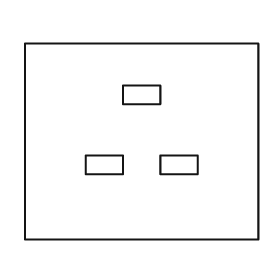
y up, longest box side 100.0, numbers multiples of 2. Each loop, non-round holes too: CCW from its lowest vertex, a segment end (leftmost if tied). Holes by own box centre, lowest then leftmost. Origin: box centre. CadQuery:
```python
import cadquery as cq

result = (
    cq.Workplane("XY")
    .moveTo(-50.0, -42.0)
    .lineTo(50.0, -42.0)
    .lineTo(50.0, 42.0)
    .lineTo(-50.0, 42.0)
    .close()
    .moveTo(-24.0, -14.0)
    .lineTo(-8.0, -14.0)
    .lineTo(-8.0, -6.0)
    .lineTo(-24.0, -6.0)
    .close()
    .moveTo(8.0, -14.0)
    .lineTo(24.0, -14.0)
    .lineTo(24.0, -6.0)
    .lineTo(8.0, -6.0)
    .close()
    .moveTo(-8.0, 16.0)
    .lineTo(8.0, 16.0)
    .lineTo(8.0, 24.0)
    .lineTo(-8.0, 24.0)
    .close()
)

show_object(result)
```